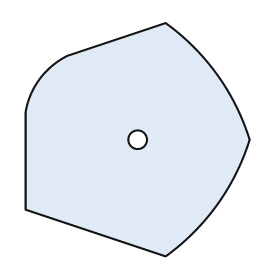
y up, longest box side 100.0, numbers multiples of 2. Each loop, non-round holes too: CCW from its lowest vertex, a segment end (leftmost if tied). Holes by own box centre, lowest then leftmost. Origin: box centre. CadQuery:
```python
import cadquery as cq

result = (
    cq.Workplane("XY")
    .moveTo(12.0, -50.0)
    .threePointArc((34.0, -28.0), (48.0, 0.0))
    .threePointArc((34.0, 28.0), (12.0, 50.0))
    .lineTo(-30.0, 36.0)
    .threePointArc((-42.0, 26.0), (-48.0, 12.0))
    .lineTo(-48.0, -30.0)
    .close()
    .moveTo(0.0, 0.0)
    .circle(4.0)
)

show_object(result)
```